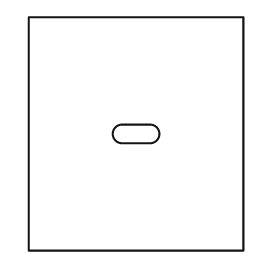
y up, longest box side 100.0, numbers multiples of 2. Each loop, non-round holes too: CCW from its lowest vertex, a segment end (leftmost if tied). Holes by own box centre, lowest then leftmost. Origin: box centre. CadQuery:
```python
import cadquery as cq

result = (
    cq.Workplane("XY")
    .moveTo(-46.0, -50.0)
    .lineTo(46.0, -50.0)
    .lineTo(46.0, 50.0)
    .lineTo(-46.0, 50.0)
    .close()
    .moveTo(-6.0, -4.0)
    .lineTo(6.0, -4.0)
    .threePointArc((10.0, 0.0), (6.0, 4.0))
    .lineTo(-6.0, 4.0)
    .threePointArc((-10.0, 0.0), (-6.0, -4.0))
    .close()
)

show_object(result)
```